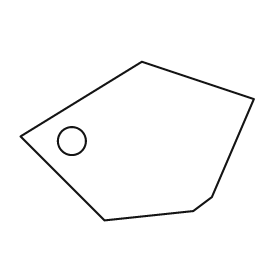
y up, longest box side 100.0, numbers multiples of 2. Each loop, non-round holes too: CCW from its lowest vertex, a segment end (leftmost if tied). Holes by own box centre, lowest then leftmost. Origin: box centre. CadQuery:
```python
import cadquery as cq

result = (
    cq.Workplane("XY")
    .moveTo(-14.0, -34.0)
    .lineTo(24.0, -30.0)
    .lineTo(32.0, -24.0)
    .lineTo(50.0, 18.0)
    .lineTo(2.0, 34.0)
    .lineTo(-50.0, 2.0)
    .close()
    .moveTo(-28.0, 0.0)
    .circle(6.0)
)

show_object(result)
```